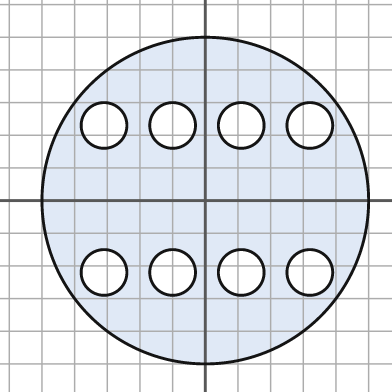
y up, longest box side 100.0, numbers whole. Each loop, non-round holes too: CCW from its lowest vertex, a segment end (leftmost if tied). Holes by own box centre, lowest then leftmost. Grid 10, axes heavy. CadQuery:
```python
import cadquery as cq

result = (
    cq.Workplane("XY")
    .moveTo(0.0, 0.0)
    .circle(50.0)
    .moveTo(-31.0, -22.0)
    .circle(7.0)
    .moveTo(-10.0, -22.0)
    .circle(7.0)
    .moveTo(11.0, -22.0)
    .circle(7.0)
    .moveTo(32.0, -22.0)
    .circle(7.0)
    .moveTo(-31.0, 23.0)
    .circle(7.0)
    .moveTo(-10.0, 23.0)
    .circle(7.0)
    .moveTo(11.0, 23.0)
    .circle(7.0)
    .moveTo(32.0, 23.0)
    .circle(7.0)
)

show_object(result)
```